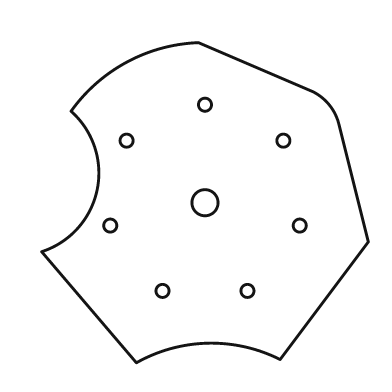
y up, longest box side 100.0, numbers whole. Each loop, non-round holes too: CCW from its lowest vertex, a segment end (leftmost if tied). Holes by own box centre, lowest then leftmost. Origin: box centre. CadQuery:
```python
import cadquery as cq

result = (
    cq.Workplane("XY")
    .moveTo(-21.0, -49.0)
    .threePointArc((1.0, -43.0), (23.0, -48.0))
    .lineTo(50.0, -12.0)
    .lineTo(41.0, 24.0)
    .threePointArc((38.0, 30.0), (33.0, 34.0))
    .lineTo(-2.0, 49.0)
    .threePointArc((-24.0, 43.0), (-41.0, 28.0))
    .threePointArc((-33.0, 4.0), (-50.0, -15.0))
    .close()
    .moveTo(-13.0, -27.0)
    .circle(2.0)
    .moveTo(13.0, -27.0)
    .circle(2.0)
    .moveTo(-29.0, -7.0)
    .circle(2.0)
    .moveTo(29.0, -7.0)
    .circle(2.0)
    .moveTo(0.0, 0.0)
    .circle(4.0)
    .moveTo(-24.0, 19.0)
    .circle(2.0)
    .moveTo(24.0, 19.0)
    .circle(2.0)
    .moveTo(0.0, 30.0)
    .circle(2.0)
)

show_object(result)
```